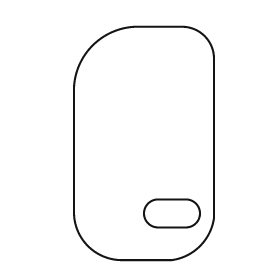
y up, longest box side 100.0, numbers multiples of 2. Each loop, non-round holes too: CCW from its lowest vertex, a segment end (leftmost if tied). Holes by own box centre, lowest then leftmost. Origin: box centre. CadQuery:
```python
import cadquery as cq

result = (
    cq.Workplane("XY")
    .moveTo(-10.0, -50.0)
    .lineTo(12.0, -50.0)
    .threePointArc((24.0, -44.0), (30.0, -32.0))
    .lineTo(30.0, 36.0)
    .threePointArc((26.0, 46.0), (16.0, 50.0))
    .lineTo(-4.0, 50.0)
    .threePointArc((-22.0, 42.0), (-30.0, 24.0))
    .lineTo(-30.0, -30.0)
    .threePointArc((-24.0, -44.0), (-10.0, -50.0))
    .close()
    .moveTo(6.0, -36.0)
    .lineTo(18.0, -36.0)
    .threePointArc((24.0, -30.0), (18.0, -24.0))
    .lineTo(6.0, -24.0)
    .threePointArc((0.0, -30.0), (6.0, -36.0))
    .close()
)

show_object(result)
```